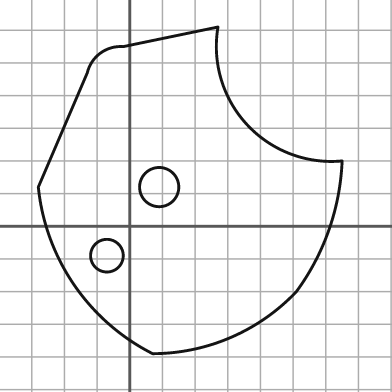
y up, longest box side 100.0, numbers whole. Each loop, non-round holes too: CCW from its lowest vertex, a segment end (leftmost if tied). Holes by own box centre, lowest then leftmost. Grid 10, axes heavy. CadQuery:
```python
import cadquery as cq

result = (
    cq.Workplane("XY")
    .moveTo(7.0, -39.0)
    .threePointArc((31.0, -34.0), (51.0, -20.0))
    .threePointArc((61.0, -1.0), (65.0, 20.0))
    .threePointArc((36.0, 31.0), (27.0, 61.0))
    .lineTo(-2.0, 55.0)
    .threePointArc((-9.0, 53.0), (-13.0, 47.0))
    .lineTo(-28.0, 12.0)
    .threePointArc((-17.0, -18.0), (7.0, -39.0))
    .close()
    .moveTo(-7.0, -9.0)
    .circle(5.0)
    .moveTo(9.0, 12.0)
    .circle(6.0)
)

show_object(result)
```